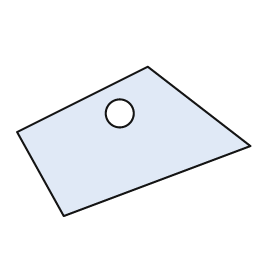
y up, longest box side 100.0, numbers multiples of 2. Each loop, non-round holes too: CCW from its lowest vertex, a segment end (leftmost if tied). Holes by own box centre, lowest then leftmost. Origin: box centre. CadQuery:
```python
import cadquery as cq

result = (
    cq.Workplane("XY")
    .moveTo(-30.0, -32.0)
    .lineTo(50.0, -2.0)
    .lineTo(6.0, 32.0)
    .lineTo(-50.0, 4.0)
    .close()
    .moveTo(-6.0, 12.0)
    .circle(6.0)
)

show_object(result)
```